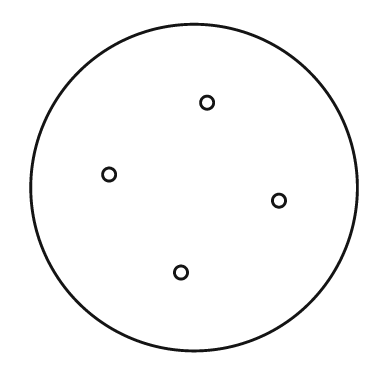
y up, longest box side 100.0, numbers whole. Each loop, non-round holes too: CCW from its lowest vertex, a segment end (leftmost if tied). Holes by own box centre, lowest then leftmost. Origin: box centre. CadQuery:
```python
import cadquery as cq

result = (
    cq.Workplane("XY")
    .moveTo(0.0, 0.0)
    .circle(50.0)
    .moveTo(-4.0, -26.0)
    .circle(2.0)
    .moveTo(26.0, -4.0)
    .circle(2.0)
    .moveTo(-26.0, 4.0)
    .circle(2.0)
    .moveTo(4.0, 26.0)
    .circle(2.0)
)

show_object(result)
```